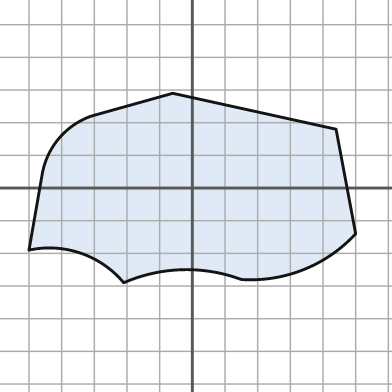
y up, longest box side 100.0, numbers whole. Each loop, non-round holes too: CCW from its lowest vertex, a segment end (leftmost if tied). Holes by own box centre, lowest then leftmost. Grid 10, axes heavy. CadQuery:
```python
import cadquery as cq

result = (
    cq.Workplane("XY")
    .moveTo(-21.0, -29.0)
    .threePointArc((-3.0, -25.0), (15.0, -28.0))
    .threePointArc((34.0, -25.0), (50.0, -14.0))
    .lineTo(44.0, 18.0)
    .lineTo(-6.0, 29.0)
    .lineTo(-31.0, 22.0)
    .threePointArc((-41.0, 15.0), (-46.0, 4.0))
    .lineTo(-50.0, -19.0)
    .threePointArc((-34.0, -20.0), (-21.0, -29.0))
    .close()
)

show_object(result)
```